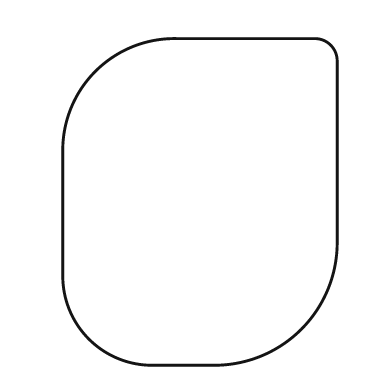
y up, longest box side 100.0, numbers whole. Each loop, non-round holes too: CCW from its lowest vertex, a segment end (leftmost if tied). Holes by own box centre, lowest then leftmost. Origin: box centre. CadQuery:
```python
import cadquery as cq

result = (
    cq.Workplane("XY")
    .moveTo(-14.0, -50.0)
    .lineTo(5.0, -50.0)
    .threePointArc((31.0, -39.0), (42.0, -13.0))
    .lineTo(42.0, 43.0)
    .threePointArc((40.0, 48.0), (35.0, 50.0))
    .lineTo(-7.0, 50.0)
    .threePointArc((-32.0, 40.0), (-42.0, 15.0))
    .lineTo(-42.0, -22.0)
    .threePointArc((-34.0, -42.0), (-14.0, -50.0))
    .close()
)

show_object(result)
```